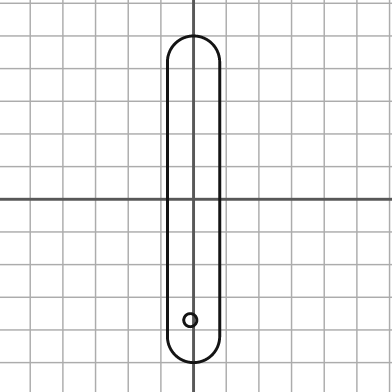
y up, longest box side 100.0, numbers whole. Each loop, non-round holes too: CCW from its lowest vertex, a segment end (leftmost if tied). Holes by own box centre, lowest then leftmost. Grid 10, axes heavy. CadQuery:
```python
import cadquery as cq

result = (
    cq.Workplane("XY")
    .moveTo(-8.0, -42.0)
    .threePointArc((0.0, -50.0), (8.0, -42.0))
    .lineTo(8.0, 42.0)
    .threePointArc((0.0, 50.0), (-8.0, 42.0))
    .close()
    .moveTo(-1.0, -37.0)
    .circle(2.0)
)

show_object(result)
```